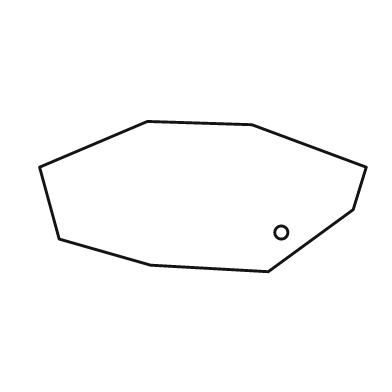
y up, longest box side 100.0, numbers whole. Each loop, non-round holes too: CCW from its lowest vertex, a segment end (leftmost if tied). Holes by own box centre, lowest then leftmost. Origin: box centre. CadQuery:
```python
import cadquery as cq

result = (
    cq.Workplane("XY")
    .moveTo(20.0, -23.0)
    .lineTo(46.0, -4.0)
    .lineTo(50.0, 9.0)
    .lineTo(15.0, 22.0)
    .lineTo(-17.0, 23.0)
    .lineTo(-50.0, 9.0)
    .lineTo(-44.0, -13.0)
    .lineTo(-16.0, -21.0)
    .close()
    .moveTo(24.0, -11.0)
    .circle(2.0)
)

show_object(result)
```